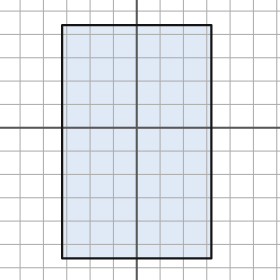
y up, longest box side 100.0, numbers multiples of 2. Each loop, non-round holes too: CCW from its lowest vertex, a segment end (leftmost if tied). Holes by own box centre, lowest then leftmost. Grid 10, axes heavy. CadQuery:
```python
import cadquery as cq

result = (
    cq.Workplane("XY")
    .moveTo(-32.0, -56.0)
    .lineTo(32.0, -56.0)
    .lineTo(32.0, 44.0)
    .lineTo(-32.0, 44.0)
    .close()
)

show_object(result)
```